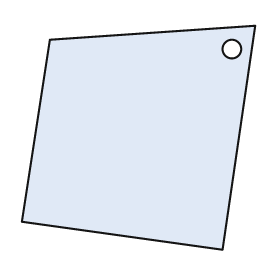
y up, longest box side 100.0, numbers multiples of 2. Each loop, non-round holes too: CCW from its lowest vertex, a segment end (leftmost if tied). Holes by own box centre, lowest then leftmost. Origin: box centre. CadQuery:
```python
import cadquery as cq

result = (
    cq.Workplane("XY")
    .moveTo(36.0, -48.0)
    .lineTo(50.0, 48.0)
    .lineTo(-38.0, 42.0)
    .lineTo(-50.0, -36.0)
    .close()
    .moveTo(40.0, 38.0)
    .circle(4.0)
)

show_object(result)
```